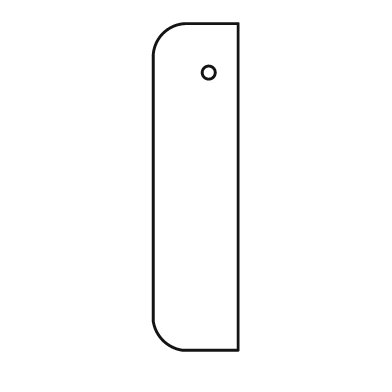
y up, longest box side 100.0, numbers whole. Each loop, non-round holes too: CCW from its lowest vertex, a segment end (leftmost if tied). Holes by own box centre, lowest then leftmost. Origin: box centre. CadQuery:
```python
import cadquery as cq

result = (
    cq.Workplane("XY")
    .moveTo(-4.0, -50.0)
    .lineTo(13.0, -50.0)
    .lineTo(13.0, 50.0)
    .lineTo(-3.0, 50.0)
    .threePointArc((-10.0, 47.0), (-13.0, 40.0))
    .lineTo(-13.0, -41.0)
    .threePointArc((-10.0, -47.0), (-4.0, -50.0))
    .close()
    .moveTo(4.0, 35.0)
    .circle(2.0)
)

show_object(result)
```